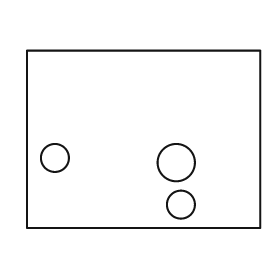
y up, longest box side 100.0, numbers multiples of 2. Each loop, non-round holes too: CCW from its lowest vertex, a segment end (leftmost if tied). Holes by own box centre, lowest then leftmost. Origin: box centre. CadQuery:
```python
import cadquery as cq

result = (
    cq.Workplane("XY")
    .moveTo(-50.0, -38.0)
    .lineTo(50.0, -38.0)
    .lineTo(50.0, 38.0)
    .lineTo(-50.0, 38.0)
    .close()
    .moveTo(16.0, -28.0)
    .circle(6.0)
    .moveTo(14.0, -10.0)
    .circle(8.0)
    .moveTo(-38.0, -8.0)
    .circle(6.0)
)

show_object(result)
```